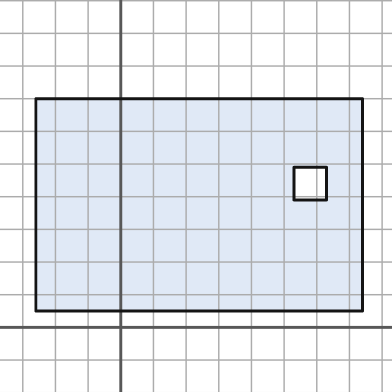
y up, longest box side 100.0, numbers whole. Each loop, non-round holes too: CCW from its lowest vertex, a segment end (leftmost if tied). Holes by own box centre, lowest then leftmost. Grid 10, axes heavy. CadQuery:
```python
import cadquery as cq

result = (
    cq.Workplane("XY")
    .moveTo(-26.0, 5.0)
    .lineTo(74.0, 5.0)
    .lineTo(74.0, 70.0)
    .lineTo(-26.0, 70.0)
    .close()
    .moveTo(53.0, 39.0)
    .lineTo(63.0, 39.0)
    .lineTo(63.0, 49.0)
    .lineTo(53.0, 49.0)
    .close()
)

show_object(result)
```